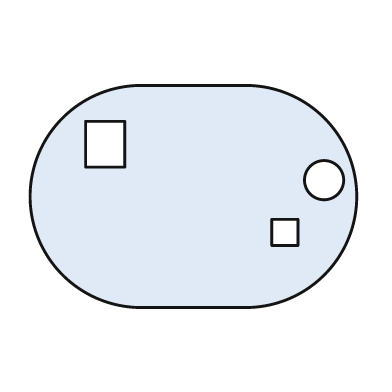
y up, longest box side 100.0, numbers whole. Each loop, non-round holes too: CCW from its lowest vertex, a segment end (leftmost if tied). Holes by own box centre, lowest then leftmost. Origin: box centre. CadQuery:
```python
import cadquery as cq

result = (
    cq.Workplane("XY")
    .moveTo(-16.0, -34.0)
    .lineTo(16.0, -34.0)
    .threePointArc((50.0, 0.0), (16.0, 34.0))
    .lineTo(-16.0, 34.0)
    .threePointArc((-50.0, 0.0), (-16.0, -34.0))
    .close()
    .moveTo(24.0, -15.0)
    .lineTo(32.0, -15.0)
    .lineTo(32.0, -7.0)
    .lineTo(24.0, -7.0)
    .close()
    .moveTo(40.0, 5.0)
    .circle(6.0)
    .moveTo(-33.0, 9.0)
    .lineTo(-21.0, 9.0)
    .lineTo(-21.0, 23.0)
    .lineTo(-33.0, 23.0)
    .close()
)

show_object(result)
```